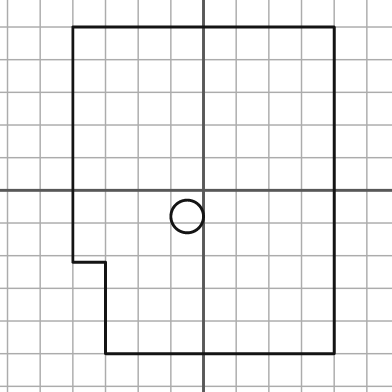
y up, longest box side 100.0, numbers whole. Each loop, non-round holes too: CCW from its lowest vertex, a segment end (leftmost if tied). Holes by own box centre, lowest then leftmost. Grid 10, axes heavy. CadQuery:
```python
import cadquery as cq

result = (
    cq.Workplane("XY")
    .moveTo(-30.0, -50.0)
    .lineTo(40.0, -50.0)
    .lineTo(40.0, 50.0)
    .lineTo(-40.0, 50.0)
    .lineTo(-40.0, -22.0)
    .lineTo(-30.0, -22.0)
    .close()
    .moveTo(-5.0, -8.0)
    .circle(5.0)
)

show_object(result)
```